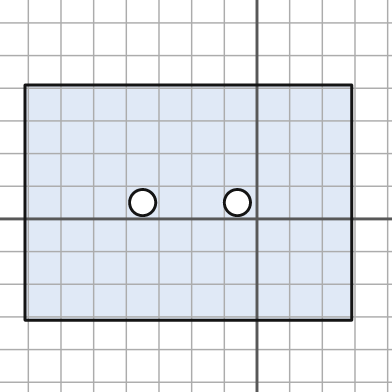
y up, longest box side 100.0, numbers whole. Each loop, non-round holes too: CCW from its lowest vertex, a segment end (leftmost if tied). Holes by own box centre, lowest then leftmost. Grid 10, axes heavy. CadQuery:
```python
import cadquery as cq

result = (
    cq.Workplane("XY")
    .moveTo(-71.0, -31.0)
    .lineTo(29.0, -31.0)
    .lineTo(29.0, 41.0)
    .lineTo(-71.0, 41.0)
    .close()
    .moveTo(-35.0, 5.0)
    .circle(4.0)
    .moveTo(-6.0, 5.0)
    .circle(4.0)
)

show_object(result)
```